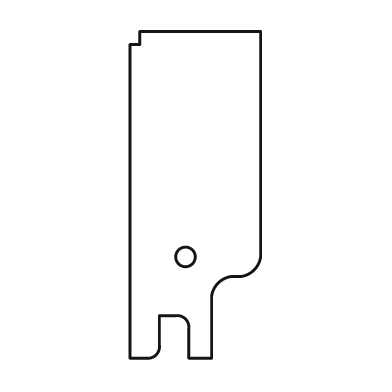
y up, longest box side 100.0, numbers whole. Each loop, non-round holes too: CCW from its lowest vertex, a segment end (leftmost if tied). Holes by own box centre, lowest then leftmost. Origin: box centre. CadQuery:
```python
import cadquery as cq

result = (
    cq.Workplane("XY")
    .moveTo(-20.0, -50.0)
    .lineTo(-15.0, -50.0)
    .threePointArc((-12.0, -49.0), (-11.0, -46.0))
    .lineTo(-11.0, -37.0)
    .lineTo(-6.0, -37.0)
    .threePointArc((-3.0, -38.0), (-2.0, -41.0))
    .lineTo(-2.0, -50.0)
    .lineTo(5.0, -50.0)
    .lineTo(5.0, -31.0)
    .threePointArc((7.0, -27.0), (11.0, -25.0))
    .lineTo(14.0, -25.0)
    .threePointArc((18.0, -23.0), (20.0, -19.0))
    .lineTo(20.0, 50.0)
    .lineTo(-17.0, 50.0)
    .lineTo(-17.0, 46.0)
    .lineTo(-20.0, 46.0)
    .close()
    .moveTo(-3.0, -19.0)
    .circle(3.0)
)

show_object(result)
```